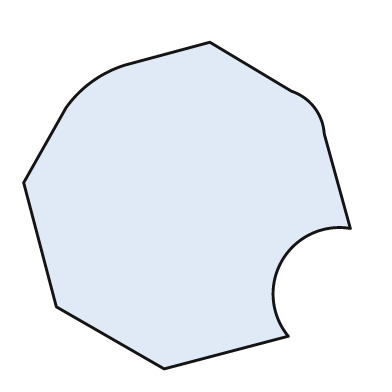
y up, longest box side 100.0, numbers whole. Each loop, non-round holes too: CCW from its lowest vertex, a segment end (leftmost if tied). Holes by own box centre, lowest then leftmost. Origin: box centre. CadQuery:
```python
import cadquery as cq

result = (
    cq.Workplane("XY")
    .moveTo(-7.0, -50.0)
    .lineTo(31.0, -40.0)
    .threePointArc((29.0, -17.0), (50.0, -7.0))
    .lineTo(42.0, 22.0)
    .threePointArc((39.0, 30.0), (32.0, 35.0))
    .lineTo(7.0, 50.0)
    .lineTo(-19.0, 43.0)
    .threePointArc((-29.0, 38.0), (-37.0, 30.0))
    .lineTo(-50.0, 7.0)
    .lineTo(-40.0, -31.0)
    .close()
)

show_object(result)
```